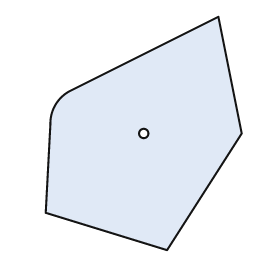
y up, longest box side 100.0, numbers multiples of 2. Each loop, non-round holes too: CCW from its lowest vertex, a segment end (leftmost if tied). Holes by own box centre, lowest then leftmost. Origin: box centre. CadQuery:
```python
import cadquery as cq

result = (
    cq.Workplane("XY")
    .moveTo(10.0, -50.0)
    .lineTo(42.0, 0.0)
    .lineTo(32.0, 50.0)
    .lineTo(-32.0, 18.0)
    .threePointArc((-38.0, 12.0), (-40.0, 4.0))
    .lineTo(-42.0, -34.0)
    .close()
    .moveTo(0.0, 0.0)
    .circle(2.0)
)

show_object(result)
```